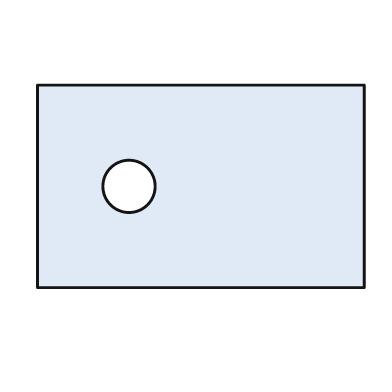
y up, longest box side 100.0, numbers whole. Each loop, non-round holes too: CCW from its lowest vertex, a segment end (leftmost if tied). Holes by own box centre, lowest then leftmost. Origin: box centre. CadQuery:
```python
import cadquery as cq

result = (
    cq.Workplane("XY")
    .moveTo(-50.0, -31.0)
    .lineTo(50.0, -31.0)
    .lineTo(50.0, 31.0)
    .lineTo(-50.0, 31.0)
    .close()
    .moveTo(-22.0, 0.0)
    .circle(8.0)
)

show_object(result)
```